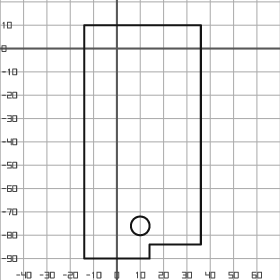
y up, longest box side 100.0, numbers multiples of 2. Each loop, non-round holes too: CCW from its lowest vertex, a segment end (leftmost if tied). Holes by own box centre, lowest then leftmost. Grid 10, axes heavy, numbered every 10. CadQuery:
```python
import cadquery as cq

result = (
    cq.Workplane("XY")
    .moveTo(-14.0, -90.0)
    .lineTo(14.0, -90.0)
    .lineTo(14.0, -84.0)
    .lineTo(36.0, -84.0)
    .lineTo(36.0, 10.0)
    .lineTo(-14.0, 10.0)
    .close()
    .moveTo(10.0, -76.0)
    .circle(4.0)
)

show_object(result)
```